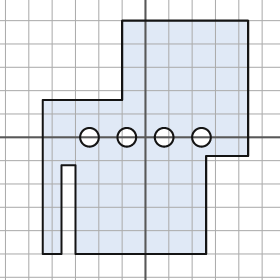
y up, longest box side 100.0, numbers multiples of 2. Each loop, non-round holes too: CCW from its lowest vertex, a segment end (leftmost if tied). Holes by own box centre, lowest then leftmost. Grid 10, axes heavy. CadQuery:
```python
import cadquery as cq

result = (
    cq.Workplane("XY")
    .moveTo(-44.0, -50.0)
    .lineTo(-36.0, -50.0)
    .lineTo(-36.0, -12.0)
    .lineTo(-30.0, -12.0)
    .lineTo(-30.0, -50.0)
    .lineTo(26.0, -50.0)
    .lineTo(26.0, -8.0)
    .lineTo(44.0, -8.0)
    .lineTo(44.0, 50.0)
    .lineTo(-10.0, 50.0)
    .lineTo(-10.0, 16.0)
    .lineTo(-44.0, 16.0)
    .close()
    .moveTo(-24.0, 0.0)
    .circle(4.0)
    .moveTo(-8.0, 0.0)
    .circle(4.0)
    .moveTo(8.0, 0.0)
    .circle(4.0)
    .moveTo(24.0, 0.0)
    .circle(4.0)
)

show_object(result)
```